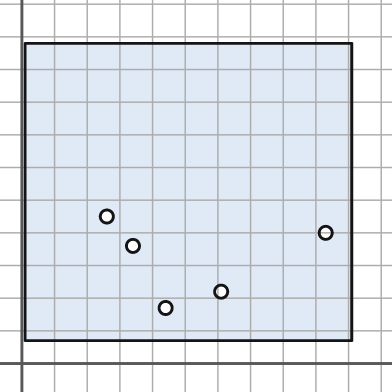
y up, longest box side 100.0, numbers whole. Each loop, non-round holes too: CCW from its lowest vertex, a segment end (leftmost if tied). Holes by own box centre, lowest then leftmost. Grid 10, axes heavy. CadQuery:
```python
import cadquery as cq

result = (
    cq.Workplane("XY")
    .moveTo(1.0, 7.0)
    .lineTo(101.0, 7.0)
    .lineTo(101.0, 98.0)
    .lineTo(1.0, 98.0)
    .close()
    .moveTo(44.0, 17.0)
    .circle(2.0)
    .moveTo(61.0, 22.0)
    .circle(2.0)
    .moveTo(34.0, 36.0)
    .circle(2.0)
    .moveTo(93.0, 40.0)
    .circle(2.0)
    .moveTo(26.0, 45.0)
    .circle(2.0)
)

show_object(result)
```